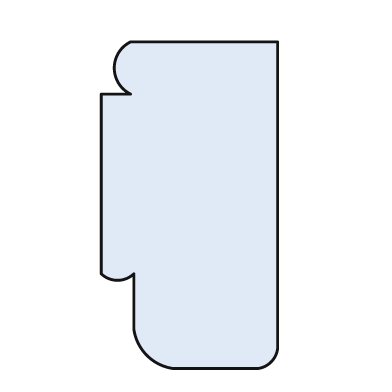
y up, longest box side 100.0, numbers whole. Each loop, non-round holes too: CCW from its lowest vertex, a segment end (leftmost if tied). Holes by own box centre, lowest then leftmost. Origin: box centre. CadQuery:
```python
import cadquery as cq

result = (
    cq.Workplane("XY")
    .moveTo(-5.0, -50.0)
    .lineTo(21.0, -50.0)
    .threePointArc((25.0, -48.0), (27.0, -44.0))
    .lineTo(27.0, 50.0)
    .lineTo(-18.0, 50.0)
    .threePointArc((-23.0, 42.0), (-18.0, 34.0))
    .lineTo(-27.0, 34.0)
    .lineTo(-27.0, -21.0)
    .threePointArc((-22.0, -23.0), (-17.0, -21.0))
    .lineTo(-17.0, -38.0)
    .threePointArc((-13.0, -46.0), (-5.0, -50.0))
    .close()
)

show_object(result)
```